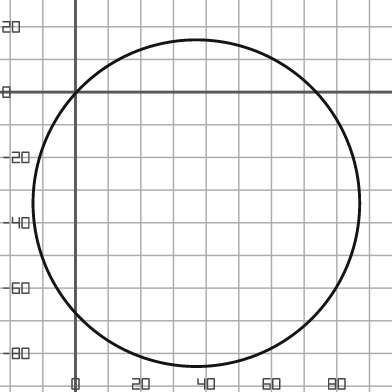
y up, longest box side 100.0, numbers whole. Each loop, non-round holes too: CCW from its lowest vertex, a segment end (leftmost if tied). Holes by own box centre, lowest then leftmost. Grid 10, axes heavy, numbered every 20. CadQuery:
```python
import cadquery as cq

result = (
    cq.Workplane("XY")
    .moveTo(37.0, -34.0)
    .circle(50.0)
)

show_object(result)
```